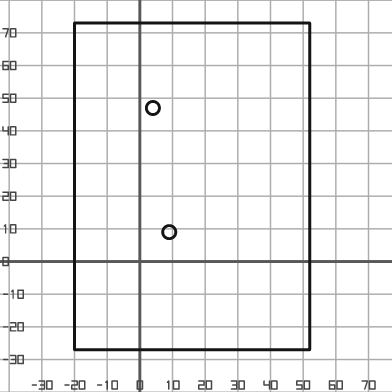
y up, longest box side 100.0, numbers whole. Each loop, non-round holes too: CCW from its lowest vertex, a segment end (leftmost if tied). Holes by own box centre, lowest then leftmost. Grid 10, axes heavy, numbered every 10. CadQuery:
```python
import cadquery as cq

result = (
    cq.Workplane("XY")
    .moveTo(-20.0, -27.0)
    .lineTo(52.0, -27.0)
    .lineTo(52.0, 73.0)
    .lineTo(-20.0, 73.0)
    .close()
    .moveTo(9.0, 9.0)
    .circle(2.0)
    .moveTo(4.0, 47.0)
    .circle(2.0)
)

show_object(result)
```